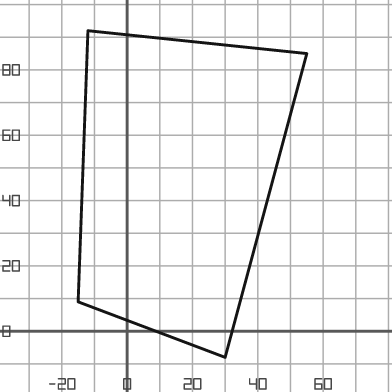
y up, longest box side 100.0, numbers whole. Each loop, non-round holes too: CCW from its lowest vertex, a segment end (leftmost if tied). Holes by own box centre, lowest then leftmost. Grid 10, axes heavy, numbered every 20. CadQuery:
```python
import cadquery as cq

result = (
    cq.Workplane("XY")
    .moveTo(30.0, -8.0)
    .lineTo(55.0, 85.0)
    .lineTo(-12.0, 92.0)
    .lineTo(-15.0, 9.0)
    .close()
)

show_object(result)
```